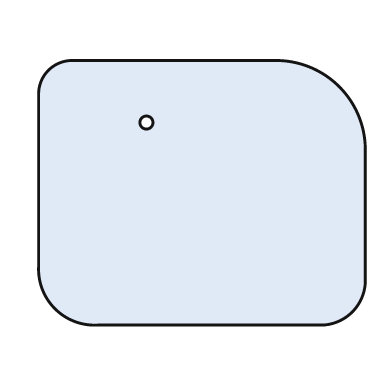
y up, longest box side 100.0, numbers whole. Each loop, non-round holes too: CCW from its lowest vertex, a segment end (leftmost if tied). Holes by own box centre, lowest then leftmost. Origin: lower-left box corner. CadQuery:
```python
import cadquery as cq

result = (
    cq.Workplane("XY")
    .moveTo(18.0, 0.0)
    .lineTo(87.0, 0.0)
    .threePointArc((96.0, 4.0), (100.0, 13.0))
    .lineTo(100.0, 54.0)
    .threePointArc((92.0, 73.0), (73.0, 81.0))
    .lineTo(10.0, 81.0)
    .threePointArc((3.0, 78.0), (0.0, 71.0))
    .lineTo(0.0, 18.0)
    .threePointArc((5.0, 5.0), (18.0, 0.0))
    .close()
    .moveTo(33.0, 62.0)
    .circle(2.0)
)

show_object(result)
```